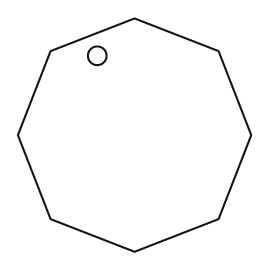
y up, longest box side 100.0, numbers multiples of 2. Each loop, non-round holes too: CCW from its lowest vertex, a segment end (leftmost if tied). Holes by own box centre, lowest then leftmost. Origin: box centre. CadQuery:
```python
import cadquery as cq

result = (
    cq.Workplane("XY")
    .moveTo(0.0, -50.0)
    .lineTo(36.0, -36.0)
    .lineTo(50.0, 0.0)
    .lineTo(36.0, 36.0)
    .lineTo(0.0, 50.0)
    .lineTo(-36.0, 36.0)
    .lineTo(-50.0, 0.0)
    .lineTo(-36.0, -36.0)
    .close()
    .moveTo(-16.0, 34.0)
    .circle(4.0)
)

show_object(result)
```